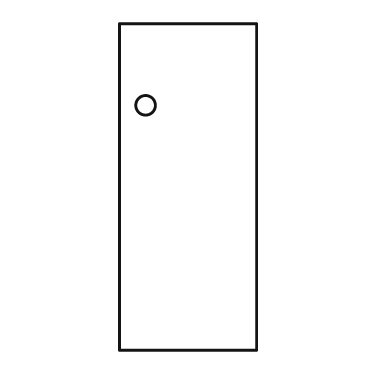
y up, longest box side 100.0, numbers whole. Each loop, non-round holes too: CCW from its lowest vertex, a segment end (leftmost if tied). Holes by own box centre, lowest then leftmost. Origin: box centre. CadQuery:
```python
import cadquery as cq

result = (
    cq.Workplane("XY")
    .moveTo(-21.0, -50.0)
    .lineTo(21.0, -50.0)
    .lineTo(21.0, 50.0)
    .lineTo(-21.0, 50.0)
    .close()
    .moveTo(-13.0, 25.0)
    .circle(3.0)
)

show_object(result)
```